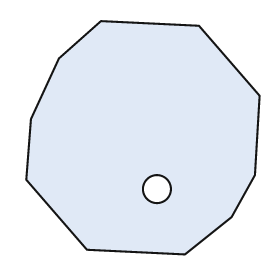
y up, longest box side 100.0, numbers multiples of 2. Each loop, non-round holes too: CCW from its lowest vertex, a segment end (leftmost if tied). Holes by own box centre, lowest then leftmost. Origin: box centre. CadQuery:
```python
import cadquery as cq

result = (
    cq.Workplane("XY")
    .moveTo(18.0, -50.0)
    .lineTo(38.0, -34.0)
    .lineTo(48.0, -16.0)
    .lineTo(50.0, 18.0)
    .lineTo(24.0, 48.0)
    .lineTo(-18.0, 50.0)
    .lineTo(-36.0, 34.0)
    .lineTo(-48.0, 8.0)
    .lineTo(-50.0, -18.0)
    .lineTo(-24.0, -48.0)
    .close()
    .moveTo(6.0, -22.0)
    .circle(6.0)
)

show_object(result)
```